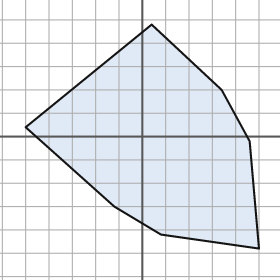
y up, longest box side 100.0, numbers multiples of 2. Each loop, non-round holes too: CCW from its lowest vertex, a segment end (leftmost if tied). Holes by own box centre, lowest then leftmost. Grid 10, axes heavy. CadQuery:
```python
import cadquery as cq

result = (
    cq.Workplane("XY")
    .moveTo(50.0, -48.0)
    .lineTo(46.0, -2.0)
    .lineTo(34.0, 20.0)
    .lineTo(4.0, 48.0)
    .lineTo(-50.0, 4.0)
    .lineTo(-12.0, -30.0)
    .lineTo(8.0, -42.0)
    .close()
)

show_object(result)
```